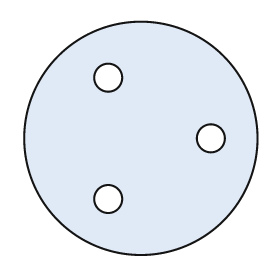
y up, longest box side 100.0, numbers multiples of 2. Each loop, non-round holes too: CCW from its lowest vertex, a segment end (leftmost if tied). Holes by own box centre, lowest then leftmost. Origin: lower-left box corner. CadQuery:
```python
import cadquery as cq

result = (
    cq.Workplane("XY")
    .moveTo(50.0, 50.0)
    .circle(50.0)
    .moveTo(36.0, 24.0)
    .circle(6.0)
    .moveTo(80.0, 50.0)
    .circle(6.0)
    .moveTo(36.0, 76.0)
    .circle(6.0)
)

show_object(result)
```